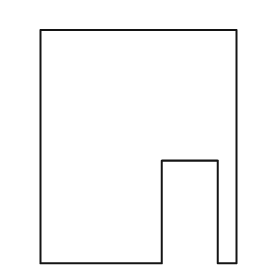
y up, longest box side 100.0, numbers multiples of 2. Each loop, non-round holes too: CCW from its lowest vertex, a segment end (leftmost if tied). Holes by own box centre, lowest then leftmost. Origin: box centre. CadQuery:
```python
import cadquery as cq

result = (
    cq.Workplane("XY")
    .moveTo(-42.0, -50.0)
    .lineTo(10.0, -50.0)
    .lineTo(10.0, -6.0)
    .lineTo(34.0, -6.0)
    .lineTo(34.0, -50.0)
    .lineTo(42.0, -50.0)
    .lineTo(42.0, 50.0)
    .lineTo(-42.0, 50.0)
    .close()
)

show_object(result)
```